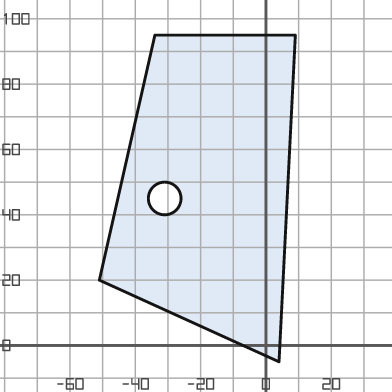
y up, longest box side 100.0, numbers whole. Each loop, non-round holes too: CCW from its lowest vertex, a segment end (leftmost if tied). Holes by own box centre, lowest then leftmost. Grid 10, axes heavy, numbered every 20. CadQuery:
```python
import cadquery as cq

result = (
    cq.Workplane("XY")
    .moveTo(4.0, -5.0)
    .lineTo(9.0, 95.0)
    .lineTo(-34.0, 95.0)
    .lineTo(-51.0, 20.0)
    .close()
    .moveTo(-31.0, 45.0)
    .circle(5.0)
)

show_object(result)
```